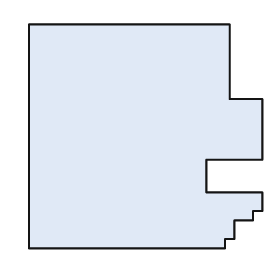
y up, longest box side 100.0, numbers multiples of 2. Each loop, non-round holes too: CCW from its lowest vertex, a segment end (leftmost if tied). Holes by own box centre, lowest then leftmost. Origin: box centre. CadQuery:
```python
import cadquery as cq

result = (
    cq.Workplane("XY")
    .moveTo(-50.0, -48.0)
    .lineTo(34.0, -48.0)
    .lineTo(34.0, -44.0)
    .lineTo(38.0, -44.0)
    .lineTo(38.0, -36.0)
    .lineTo(46.0, -36.0)
    .lineTo(46.0, -32.0)
    .lineTo(50.0, -32.0)
    .lineTo(50.0, -24.0)
    .lineTo(26.0, -24.0)
    .lineTo(26.0, -10.0)
    .lineTo(50.0, -10.0)
    .lineTo(50.0, 16.0)
    .lineTo(36.0, 16.0)
    .lineTo(36.0, 48.0)
    .lineTo(-50.0, 48.0)
    .close()
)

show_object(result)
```